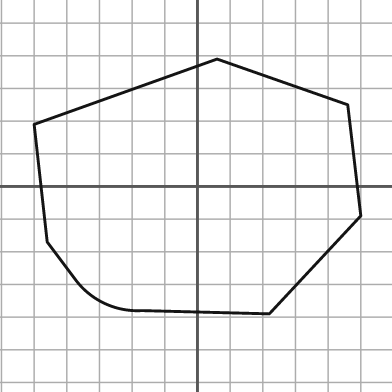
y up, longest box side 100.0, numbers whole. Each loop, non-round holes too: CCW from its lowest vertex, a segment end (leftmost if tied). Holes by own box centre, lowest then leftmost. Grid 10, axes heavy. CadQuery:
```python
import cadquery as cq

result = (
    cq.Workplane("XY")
    .moveTo(22.0, -39.0)
    .lineTo(50.0, -9.0)
    .lineTo(46.0, 25.0)
    .lineTo(6.0, 39.0)
    .lineTo(-50.0, 19.0)
    .lineTo(-46.0, -17.0)
    .lineTo(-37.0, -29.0)
    .threePointArc((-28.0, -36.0), (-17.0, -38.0))
    .close()
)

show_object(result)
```